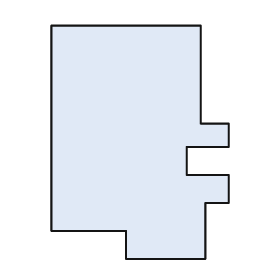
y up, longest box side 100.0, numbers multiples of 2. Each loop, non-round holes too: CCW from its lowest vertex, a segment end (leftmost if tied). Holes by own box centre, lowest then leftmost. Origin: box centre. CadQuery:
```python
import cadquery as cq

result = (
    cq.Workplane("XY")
    .moveTo(-6.0, -50.0)
    .lineTo(28.0, -50.0)
    .lineTo(28.0, -26.0)
    .lineTo(38.0, -26.0)
    .lineTo(38.0, -14.0)
    .lineTo(20.0, -14.0)
    .lineTo(20.0, -2.0)
    .lineTo(38.0, -2.0)
    .lineTo(38.0, 8.0)
    .lineTo(26.0, 8.0)
    .lineTo(26.0, 50.0)
    .lineTo(-38.0, 50.0)
    .lineTo(-38.0, -38.0)
    .lineTo(-6.0, -38.0)
    .close()
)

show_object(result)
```